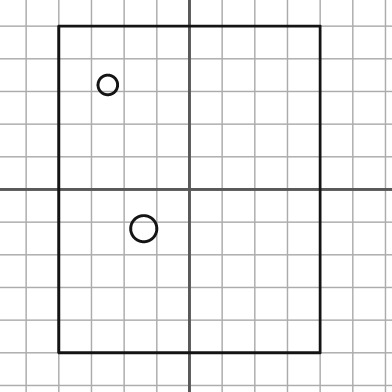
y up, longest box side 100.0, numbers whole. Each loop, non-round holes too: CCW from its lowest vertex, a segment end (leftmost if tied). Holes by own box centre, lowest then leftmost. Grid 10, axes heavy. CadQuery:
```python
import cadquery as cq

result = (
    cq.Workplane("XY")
    .moveTo(-40.0, -50.0)
    .lineTo(40.0, -50.0)
    .lineTo(40.0, 50.0)
    .lineTo(-40.0, 50.0)
    .close()
    .moveTo(-14.0, -12.0)
    .circle(4.0)
    .moveTo(-25.0, 32.0)
    .circle(3.0)
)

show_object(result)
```